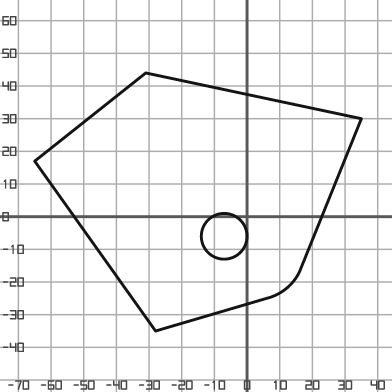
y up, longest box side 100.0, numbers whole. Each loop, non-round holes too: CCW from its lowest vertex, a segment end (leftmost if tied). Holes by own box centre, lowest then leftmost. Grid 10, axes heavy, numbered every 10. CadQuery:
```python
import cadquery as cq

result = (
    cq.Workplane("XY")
    .moveTo(-28.0, -35.0)
    .lineTo(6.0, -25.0)
    .threePointArc((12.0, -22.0), (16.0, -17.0))
    .lineTo(35.0, 30.0)
    .lineTo(-31.0, 44.0)
    .lineTo(-65.0, 17.0)
    .close()
    .moveTo(-7.0, -6.0)
    .circle(7.0)
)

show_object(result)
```